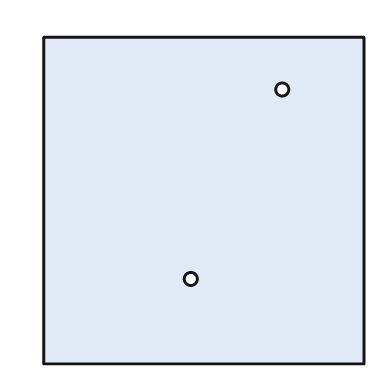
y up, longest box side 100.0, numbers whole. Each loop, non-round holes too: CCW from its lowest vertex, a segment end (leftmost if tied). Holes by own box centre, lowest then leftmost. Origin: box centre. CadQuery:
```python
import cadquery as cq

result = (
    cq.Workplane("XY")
    .moveTo(-49.0, -50.0)
    .lineTo(49.0, -50.0)
    .lineTo(49.0, 50.0)
    .lineTo(-49.0, 50.0)
    .close()
    .moveTo(-4.0, -24.0)
    .circle(2.0)
    .moveTo(24.0, 34.0)
    .circle(2.0)
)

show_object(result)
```